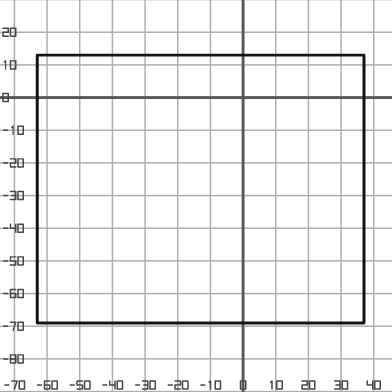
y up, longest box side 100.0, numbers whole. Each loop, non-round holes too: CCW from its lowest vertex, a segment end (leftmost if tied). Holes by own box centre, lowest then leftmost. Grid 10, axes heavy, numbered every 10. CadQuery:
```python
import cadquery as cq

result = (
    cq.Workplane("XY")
    .moveTo(-63.0, -69.0)
    .lineTo(37.0, -69.0)
    .lineTo(37.0, 13.0)
    .lineTo(-63.0, 13.0)
    .close()
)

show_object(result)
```